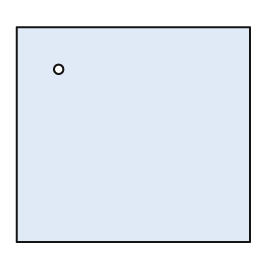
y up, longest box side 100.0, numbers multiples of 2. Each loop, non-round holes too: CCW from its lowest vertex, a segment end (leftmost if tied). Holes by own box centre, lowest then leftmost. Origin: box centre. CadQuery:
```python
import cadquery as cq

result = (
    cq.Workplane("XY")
    .moveTo(-50.0, -46.0)
    .lineTo(50.0, -46.0)
    .lineTo(50.0, 46.0)
    .lineTo(-50.0, 46.0)
    .close()
    .moveTo(-32.0, 28.0)
    .circle(2.0)
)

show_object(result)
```